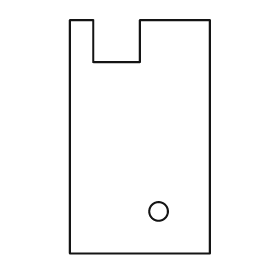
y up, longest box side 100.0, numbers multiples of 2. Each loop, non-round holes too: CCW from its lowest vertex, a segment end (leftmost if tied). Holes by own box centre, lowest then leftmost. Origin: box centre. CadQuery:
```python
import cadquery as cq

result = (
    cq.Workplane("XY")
    .moveTo(-30.0, -50.0)
    .lineTo(30.0, -50.0)
    .lineTo(30.0, 50.0)
    .lineTo(0.0, 50.0)
    .lineTo(0.0, 32.0)
    .lineTo(-20.0, 32.0)
    .lineTo(-20.0, 50.0)
    .lineTo(-30.0, 50.0)
    .close()
    .moveTo(8.0, -32.0)
    .circle(4.0)
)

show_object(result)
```